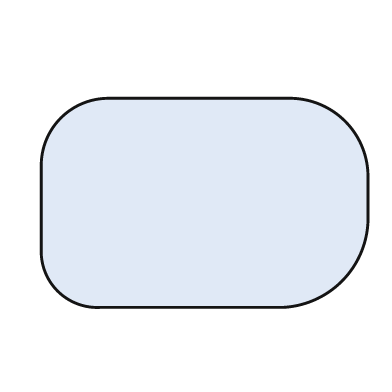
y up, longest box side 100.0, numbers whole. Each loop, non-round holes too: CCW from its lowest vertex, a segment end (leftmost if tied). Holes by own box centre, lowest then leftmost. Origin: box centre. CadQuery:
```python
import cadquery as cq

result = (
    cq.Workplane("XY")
    .moveTo(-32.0, -32.0)
    .lineTo(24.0, -32.0)
    .threePointArc((42.0, -24.0), (50.0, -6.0))
    .lineTo(50.0, 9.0)
    .threePointArc((43.0, 25.0), (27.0, 32.0))
    .lineTo(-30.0, 32.0)
    .threePointArc((-44.0, 26.0), (-50.0, 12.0))
    .lineTo(-50.0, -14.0)
    .threePointArc((-45.0, -27.0), (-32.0, -32.0))
    .close()
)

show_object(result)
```